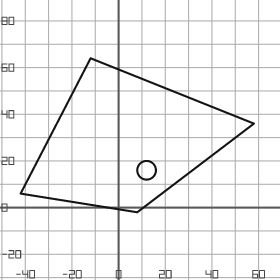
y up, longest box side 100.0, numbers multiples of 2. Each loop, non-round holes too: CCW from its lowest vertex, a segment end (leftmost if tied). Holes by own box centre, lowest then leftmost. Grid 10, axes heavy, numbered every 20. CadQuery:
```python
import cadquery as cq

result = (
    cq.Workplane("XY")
    .moveTo(8.0, -2.0)
    .lineTo(58.0, 36.0)
    .lineTo(-12.0, 64.0)
    .lineTo(-42.0, 6.0)
    .close()
    .moveTo(12.0, 16.0)
    .circle(4.0)
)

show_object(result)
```